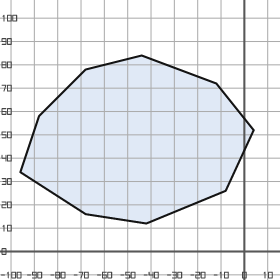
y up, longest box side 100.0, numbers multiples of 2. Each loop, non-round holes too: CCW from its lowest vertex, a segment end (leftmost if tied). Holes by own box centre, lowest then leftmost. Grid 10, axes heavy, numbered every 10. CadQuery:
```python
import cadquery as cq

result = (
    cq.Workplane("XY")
    .moveTo(-42.0, 12.0)
    .lineTo(-8.0, 26.0)
    .lineTo(4.0, 52.0)
    .lineTo(-12.0, 72.0)
    .lineTo(-44.0, 84.0)
    .lineTo(-68.0, 78.0)
    .lineTo(-88.0, 58.0)
    .lineTo(-96.0, 34.0)
    .lineTo(-68.0, 16.0)
    .close()
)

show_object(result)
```